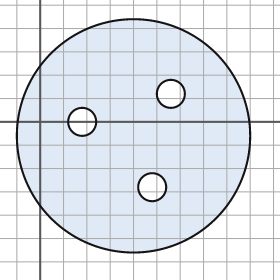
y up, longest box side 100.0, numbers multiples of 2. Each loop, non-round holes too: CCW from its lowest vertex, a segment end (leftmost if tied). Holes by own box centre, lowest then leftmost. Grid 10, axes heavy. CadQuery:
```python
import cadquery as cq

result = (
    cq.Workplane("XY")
    .moveTo(40.0, -6.0)
    .circle(50.0)
    .moveTo(48.0, -28.0)
    .circle(6.0)
    .moveTo(18.0, 0.0)
    .circle(6.0)
    .moveTo(56.0, 12.0)
    .circle(6.0)
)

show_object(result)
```